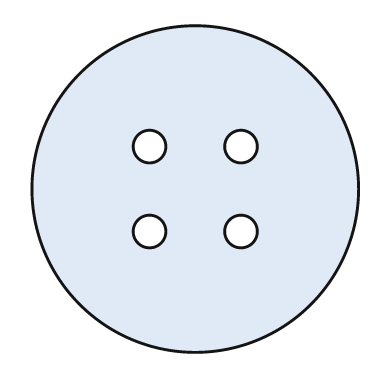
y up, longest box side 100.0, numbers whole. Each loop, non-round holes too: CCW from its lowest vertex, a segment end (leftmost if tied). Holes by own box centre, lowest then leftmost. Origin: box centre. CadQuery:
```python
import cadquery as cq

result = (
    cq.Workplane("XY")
    .moveTo(0.0, 0.0)
    .circle(50.0)
    .moveTo(-14.0, -13.0)
    .circle(5.0)
    .moveTo(14.0, -13.0)
    .circle(5.0)
    .moveTo(-14.0, 13.0)
    .circle(5.0)
    .moveTo(14.0, 13.0)
    .circle(5.0)
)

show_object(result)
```